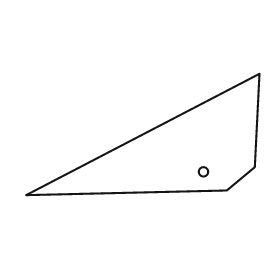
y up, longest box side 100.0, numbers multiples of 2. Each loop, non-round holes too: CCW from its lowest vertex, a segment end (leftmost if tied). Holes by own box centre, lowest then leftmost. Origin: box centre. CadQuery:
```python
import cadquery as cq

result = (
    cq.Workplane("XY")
    .moveTo(-50.0, -26.0)
    .lineTo(36.0, -24.0)
    .lineTo(48.0, -14.0)
    .lineTo(50.0, 26.0)
    .close()
    .moveTo(26.0, -16.0)
    .circle(2.0)
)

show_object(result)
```